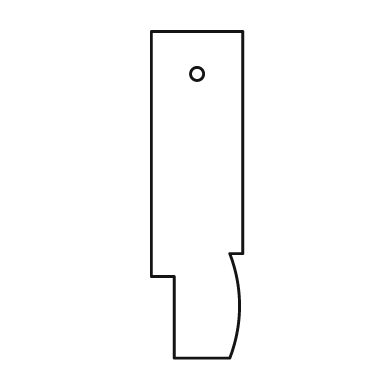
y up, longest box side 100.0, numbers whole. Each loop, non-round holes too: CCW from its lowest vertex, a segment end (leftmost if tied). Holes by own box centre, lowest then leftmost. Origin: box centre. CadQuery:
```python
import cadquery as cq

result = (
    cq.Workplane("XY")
    .moveTo(-7.0, -50.0)
    .lineTo(10.0, -50.0)
    .threePointArc((13.0, -34.0), (10.0, -18.0))
    .lineTo(14.0, -18.0)
    .lineTo(14.0, 50.0)
    .lineTo(-14.0, 50.0)
    .lineTo(-14.0, -25.0)
    .lineTo(-7.0, -25.0)
    .close()
    .moveTo(0.0, 37.0)
    .circle(2.0)
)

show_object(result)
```